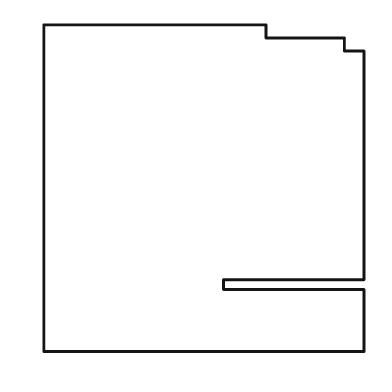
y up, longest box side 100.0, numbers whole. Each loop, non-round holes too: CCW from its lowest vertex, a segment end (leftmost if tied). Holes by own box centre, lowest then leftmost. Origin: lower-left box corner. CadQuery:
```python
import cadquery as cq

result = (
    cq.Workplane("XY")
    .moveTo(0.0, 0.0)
    .lineTo(98.0, 0.0)
    .lineTo(98.0, 19.0)
    .lineTo(55.0, 19.0)
    .lineTo(55.0, 22.0)
    .lineTo(98.0, 22.0)
    .lineTo(98.0, 92.0)
    .lineTo(92.0, 92.0)
    .lineTo(92.0, 96.0)
    .lineTo(68.0, 96.0)
    .lineTo(68.0, 100.0)
    .lineTo(0.0, 100.0)
    .close()
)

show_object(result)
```